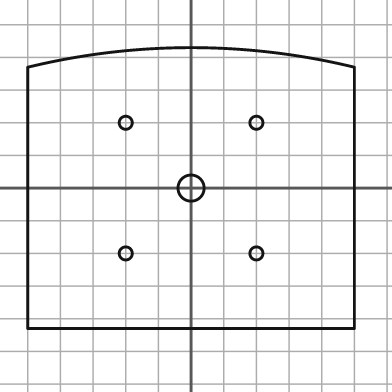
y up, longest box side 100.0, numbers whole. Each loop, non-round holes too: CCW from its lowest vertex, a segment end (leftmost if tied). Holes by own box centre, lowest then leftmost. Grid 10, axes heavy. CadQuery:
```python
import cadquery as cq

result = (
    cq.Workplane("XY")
    .moveTo(-50.0, -43.0)
    .lineTo(50.0, -43.0)
    .lineTo(50.0, 37.0)
    .threePointArc((0.0, 43.0), (-50.0, 37.0))
    .close()
    .moveTo(-20.0, -20.0)
    .circle(2.0)
    .moveTo(20.0, -20.0)
    .circle(2.0)
    .moveTo(0.0, 0.0)
    .circle(4.0)
    .moveTo(-20.0, 20.0)
    .circle(2.0)
    .moveTo(20.0, 20.0)
    .circle(2.0)
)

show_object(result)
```